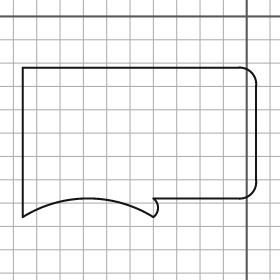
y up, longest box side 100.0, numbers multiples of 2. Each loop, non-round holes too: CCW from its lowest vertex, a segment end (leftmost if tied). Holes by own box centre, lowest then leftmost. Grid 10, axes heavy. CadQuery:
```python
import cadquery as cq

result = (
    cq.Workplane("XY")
    .moveTo(-96.0, -86.0)
    .threePointArc((-68.0, -78.0), (-40.0, -86.0))
    .threePointArc((-38.0, -82.0), (-40.0, -78.0))
    .lineTo(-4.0, -78.0)
    .threePointArc((2.0, -76.0), (4.0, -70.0))
    .lineTo(4.0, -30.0)
    .threePointArc((2.0, -24.0), (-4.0, -22.0))
    .lineTo(-96.0, -22.0)
    .close()
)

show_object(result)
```